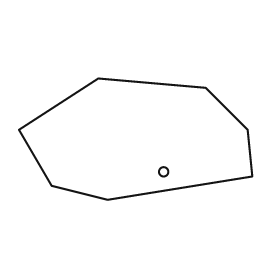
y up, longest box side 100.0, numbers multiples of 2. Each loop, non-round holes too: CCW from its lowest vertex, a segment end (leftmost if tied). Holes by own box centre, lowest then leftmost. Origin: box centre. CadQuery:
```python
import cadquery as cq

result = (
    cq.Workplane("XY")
    .moveTo(-12.0, -26.0)
    .lineTo(50.0, -16.0)
    .lineTo(48.0, 4.0)
    .lineTo(30.0, 22.0)
    .lineTo(-16.0, 26.0)
    .lineTo(-50.0, 4.0)
    .lineTo(-36.0, -20.0)
    .close()
    .moveTo(12.0, -14.0)
    .circle(2.0)
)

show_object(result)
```